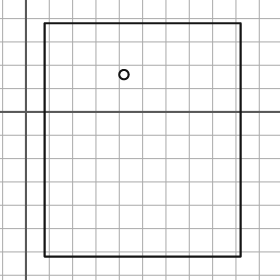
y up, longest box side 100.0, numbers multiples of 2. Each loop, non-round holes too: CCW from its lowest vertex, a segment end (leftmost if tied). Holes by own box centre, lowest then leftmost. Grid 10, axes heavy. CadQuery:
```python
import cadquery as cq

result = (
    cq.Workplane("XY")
    .moveTo(8.0, -62.0)
    .lineTo(92.0, -62.0)
    .lineTo(92.0, 38.0)
    .lineTo(8.0, 38.0)
    .close()
    .moveTo(42.0, 16.0)
    .circle(2.0)
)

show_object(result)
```